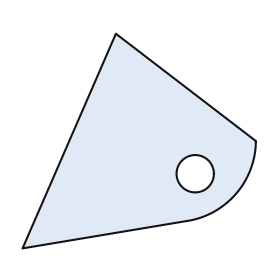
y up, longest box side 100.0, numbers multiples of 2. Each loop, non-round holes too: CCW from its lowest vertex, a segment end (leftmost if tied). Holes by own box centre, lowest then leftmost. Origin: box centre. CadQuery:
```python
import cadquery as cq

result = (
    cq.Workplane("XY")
    .moveTo(-50.0, -46.0)
    .lineTo(22.0, -34.0)
    .threePointArc((42.0, -22.0), (50.0, 0.0))
    .lineTo(-10.0, 46.0)
    .close()
    .moveTo(24.0, -14.0)
    .circle(8.0)
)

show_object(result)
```